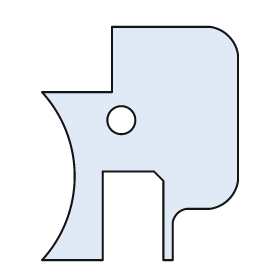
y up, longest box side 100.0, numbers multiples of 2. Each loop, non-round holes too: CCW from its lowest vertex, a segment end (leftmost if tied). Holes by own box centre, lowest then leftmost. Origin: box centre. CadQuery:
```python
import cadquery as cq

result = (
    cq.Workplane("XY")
    .moveTo(-42.0, -50.0)
    .lineTo(-16.0, -50.0)
    .lineTo(-16.0, -12.0)
    .lineTo(6.0, -12.0)
    .lineTo(10.0, -16.0)
    .lineTo(10.0, -50.0)
    .lineTo(14.0, -50.0)
    .lineTo(14.0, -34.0)
    .threePointArc((16.0, -30.0), (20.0, -28.0))
    .lineTo(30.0, -28.0)
    .threePointArc((38.0, -24.0), (42.0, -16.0))
    .lineTo(42.0, 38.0)
    .threePointArc((38.0, 46.0), (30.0, 50.0))
    .lineTo(-12.0, 50.0)
    .lineTo(-12.0, 22.0)
    .lineTo(-42.0, 22.0)
    .threePointArc((-28.0, -14.0), (-42.0, -50.0))
    .close()
    .moveTo(-8.0, 10.0)
    .circle(6.0)
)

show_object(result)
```